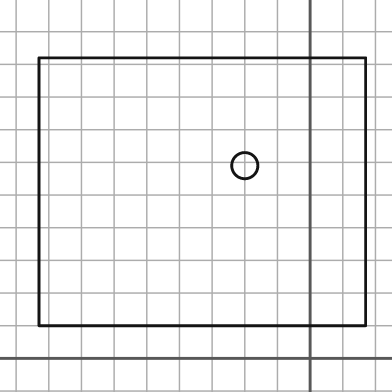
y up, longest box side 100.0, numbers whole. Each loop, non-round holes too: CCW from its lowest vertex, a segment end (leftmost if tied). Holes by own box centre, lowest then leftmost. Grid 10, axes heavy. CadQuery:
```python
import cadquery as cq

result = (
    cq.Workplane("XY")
    .moveTo(-83.0, 10.0)
    .lineTo(17.0, 10.0)
    .lineTo(17.0, 92.0)
    .lineTo(-83.0, 92.0)
    .close()
    .moveTo(-20.0, 59.0)
    .circle(4.0)
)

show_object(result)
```